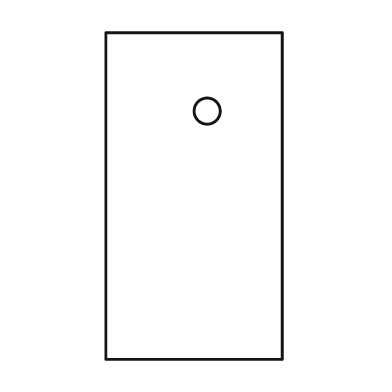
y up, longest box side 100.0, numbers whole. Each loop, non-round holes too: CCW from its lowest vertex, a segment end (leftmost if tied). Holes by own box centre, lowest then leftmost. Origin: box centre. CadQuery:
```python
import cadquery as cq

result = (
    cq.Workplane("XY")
    .moveTo(-27.0, -50.0)
    .lineTo(27.0, -50.0)
    .lineTo(27.0, 50.0)
    .lineTo(-27.0, 50.0)
    .close()
    .moveTo(4.0, 26.0)
    .circle(4.0)
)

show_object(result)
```